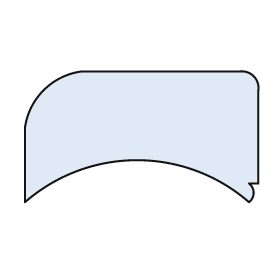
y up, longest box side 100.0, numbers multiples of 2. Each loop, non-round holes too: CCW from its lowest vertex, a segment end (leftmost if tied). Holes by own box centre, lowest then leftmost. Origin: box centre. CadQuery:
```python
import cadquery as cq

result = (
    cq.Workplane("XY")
    .moveTo(-50.0, -28.0)
    .threePointArc((-2.0, -10.0), (46.0, -28.0))
    .threePointArc((48.0, -24.0), (46.0, -20.0))
    .lineTo(50.0, -20.0)
    .lineTo(50.0, 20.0)
    .threePointArc((48.0, 26.0), (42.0, 28.0))
    .lineTo(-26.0, 28.0)
    .threePointArc((-42.0, 20.0), (-50.0, 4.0))
    .close()
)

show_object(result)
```